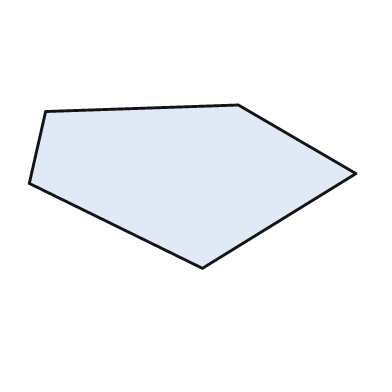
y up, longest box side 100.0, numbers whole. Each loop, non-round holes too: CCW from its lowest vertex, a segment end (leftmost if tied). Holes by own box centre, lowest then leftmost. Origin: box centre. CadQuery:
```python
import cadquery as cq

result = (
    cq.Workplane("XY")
    .moveTo(3.0, -25.0)
    .lineTo(50.0, 4.0)
    .lineTo(14.0, 25.0)
    .lineTo(-45.0, 23.0)
    .lineTo(-50.0, 1.0)
    .close()
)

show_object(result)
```